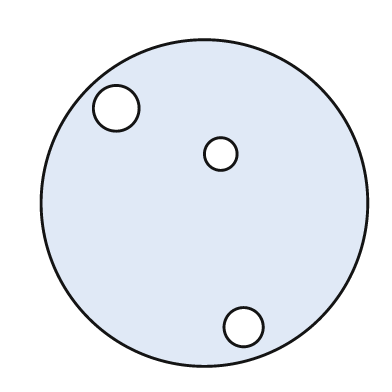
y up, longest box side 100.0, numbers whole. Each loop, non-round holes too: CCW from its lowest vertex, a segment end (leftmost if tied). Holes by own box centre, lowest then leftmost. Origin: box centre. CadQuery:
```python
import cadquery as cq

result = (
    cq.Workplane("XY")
    .moveTo(0.0, 0.0)
    .circle(50.0)
    .moveTo(12.0, -38.0)
    .circle(6.0)
    .moveTo(5.0, 15.0)
    .circle(5.0)
    .moveTo(-27.0, 29.0)
    .circle(7.0)
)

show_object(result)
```